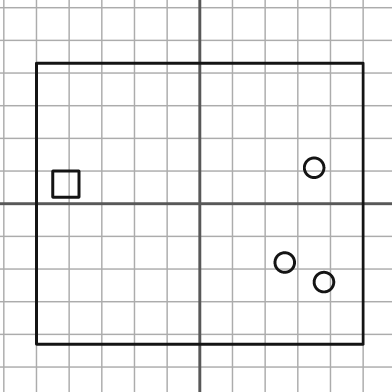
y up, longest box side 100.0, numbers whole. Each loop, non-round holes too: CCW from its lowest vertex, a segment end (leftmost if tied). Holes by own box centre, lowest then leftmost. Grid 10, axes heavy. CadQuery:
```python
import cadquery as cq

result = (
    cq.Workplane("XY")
    .moveTo(-50.0, -43.0)
    .lineTo(50.0, -43.0)
    .lineTo(50.0, 43.0)
    .lineTo(-50.0, 43.0)
    .close()
    .moveTo(38.0, -24.0)
    .circle(3.0)
    .moveTo(26.0, -18.0)
    .circle(3.0)
    .moveTo(-45.0, 2.0)
    .lineTo(-37.0, 2.0)
    .lineTo(-37.0, 10.0)
    .lineTo(-45.0, 10.0)
    .close()
    .moveTo(35.0, 11.0)
    .circle(3.0)
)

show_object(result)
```